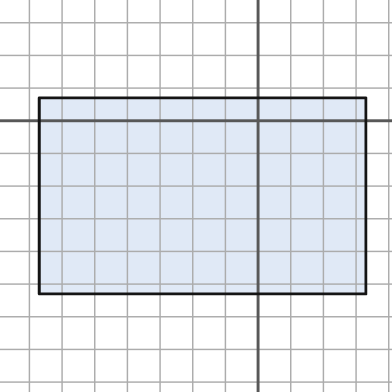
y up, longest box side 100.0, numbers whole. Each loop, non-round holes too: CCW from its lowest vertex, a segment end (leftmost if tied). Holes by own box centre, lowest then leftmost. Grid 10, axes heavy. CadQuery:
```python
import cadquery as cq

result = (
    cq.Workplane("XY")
    .moveTo(-67.0, -53.0)
    .lineTo(33.0, -53.0)
    .lineTo(33.0, 7.0)
    .lineTo(-67.0, 7.0)
    .close()
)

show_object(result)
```